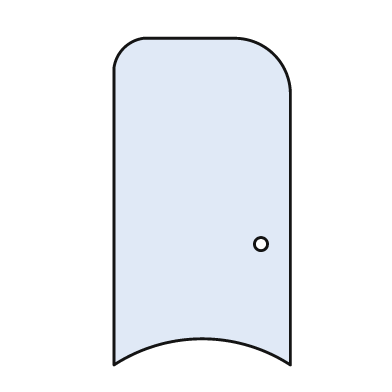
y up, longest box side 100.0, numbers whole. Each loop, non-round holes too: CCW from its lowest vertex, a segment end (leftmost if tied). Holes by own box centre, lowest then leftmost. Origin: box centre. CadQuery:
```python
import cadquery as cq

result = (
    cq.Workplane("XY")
    .moveTo(-27.0, -50.0)
    .threePointArc((0.0, -42.0), (27.0, -50.0))
    .lineTo(27.0, 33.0)
    .threePointArc((22.0, 45.0), (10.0, 50.0))
    .lineTo(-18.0, 50.0)
    .threePointArc((-24.0, 47.0), (-27.0, 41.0))
    .close()
    .moveTo(18.0, -13.0)
    .circle(2.0)
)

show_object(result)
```